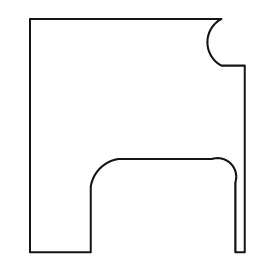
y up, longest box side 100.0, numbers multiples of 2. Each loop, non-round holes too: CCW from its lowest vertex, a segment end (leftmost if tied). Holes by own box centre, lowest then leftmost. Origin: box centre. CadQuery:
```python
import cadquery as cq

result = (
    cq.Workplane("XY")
    .moveTo(-46.0, -50.0)
    .lineTo(-20.0, -50.0)
    .lineTo(-20.0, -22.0)
    .threePointArc((-16.0, -14.0), (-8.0, -10.0))
    .lineTo(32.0, -10.0)
    .threePointArc((40.0, -12.0), (42.0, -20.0))
    .lineTo(42.0, -50.0)
    .lineTo(46.0, -50.0)
    .lineTo(46.0, 30.0)
    .lineTo(36.0, 30.0)
    .threePointArc((30.0, 40.0), (36.0, 50.0))
    .lineTo(-46.0, 50.0)
    .close()
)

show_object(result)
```